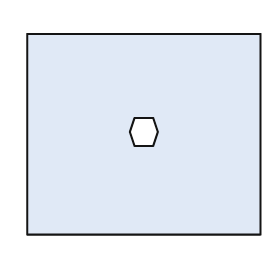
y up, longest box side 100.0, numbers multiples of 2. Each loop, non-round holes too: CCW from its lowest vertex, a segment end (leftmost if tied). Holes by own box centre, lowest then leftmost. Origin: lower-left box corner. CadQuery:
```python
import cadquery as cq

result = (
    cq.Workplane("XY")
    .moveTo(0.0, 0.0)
    .lineTo(100.0, 0.0)
    .lineTo(100.0, 86.0)
    .lineTo(0.0, 86.0)
    .close()
    .moveTo(46.0, 38.0)
    .lineTo(54.0, 38.0)
    .lineTo(56.0, 44.0)
    .lineTo(54.0, 50.0)
    .lineTo(46.0, 50.0)
    .lineTo(44.0, 44.0)
    .close()
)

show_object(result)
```